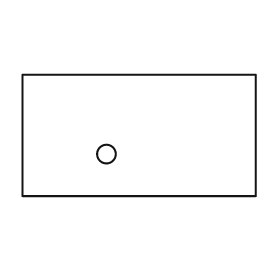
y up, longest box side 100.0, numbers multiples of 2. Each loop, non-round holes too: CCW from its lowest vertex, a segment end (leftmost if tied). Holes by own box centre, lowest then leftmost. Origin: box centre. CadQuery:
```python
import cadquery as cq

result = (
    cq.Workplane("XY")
    .moveTo(-50.0, -26.0)
    .lineTo(50.0, -26.0)
    .lineTo(50.0, 26.0)
    .lineTo(-50.0, 26.0)
    .close()
    .moveTo(-14.0, -8.0)
    .circle(4.0)
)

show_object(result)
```